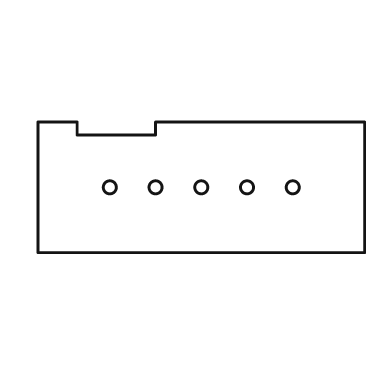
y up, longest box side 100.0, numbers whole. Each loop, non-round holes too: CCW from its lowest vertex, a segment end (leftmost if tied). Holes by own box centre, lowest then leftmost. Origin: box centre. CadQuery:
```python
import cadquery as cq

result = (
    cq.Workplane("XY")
    .moveTo(-50.0, -20.0)
    .lineTo(50.0, -20.0)
    .lineTo(50.0, 20.0)
    .lineTo(-14.0, 20.0)
    .lineTo(-14.0, 16.0)
    .lineTo(-38.0, 16.0)
    .lineTo(-38.0, 20.0)
    .lineTo(-50.0, 20.0)
    .close()
    .moveTo(-28.0, 0.0)
    .circle(2.0)
    .moveTo(-14.0, 0.0)
    .circle(2.0)
    .moveTo(0.0, 0.0)
    .circle(2.0)
    .moveTo(14.0, 0.0)
    .circle(2.0)
    .moveTo(28.0, 0.0)
    .circle(2.0)
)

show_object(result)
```